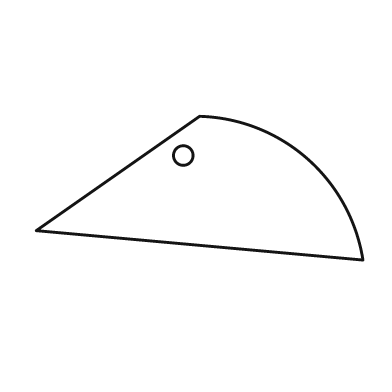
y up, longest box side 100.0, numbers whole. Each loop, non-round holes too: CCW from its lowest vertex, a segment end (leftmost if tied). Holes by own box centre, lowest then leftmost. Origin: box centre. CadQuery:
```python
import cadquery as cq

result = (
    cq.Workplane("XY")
    .moveTo(50.0, -22.0)
    .threePointArc((33.0, 9.0), (0.0, 22.0))
    .lineTo(-50.0, -13.0)
    .close()
    .moveTo(-5.0, 10.0)
    .circle(3.0)
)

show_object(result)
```